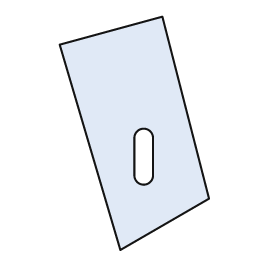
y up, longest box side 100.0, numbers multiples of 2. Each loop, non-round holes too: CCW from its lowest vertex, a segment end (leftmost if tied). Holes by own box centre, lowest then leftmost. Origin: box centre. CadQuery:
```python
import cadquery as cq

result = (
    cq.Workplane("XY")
    .moveTo(-6.0, -50.0)
    .lineTo(32.0, -28.0)
    .lineTo(12.0, 50.0)
    .lineTo(-32.0, 38.0)
    .close()
    .moveTo(0.0, -18.0)
    .threePointArc((4.0, -22.0), (8.0, -18.0))
    .lineTo(8.0, -2.0)
    .threePointArc((4.0, 2.0), (0.0, -2.0))
    .close()
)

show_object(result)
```